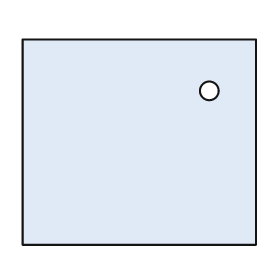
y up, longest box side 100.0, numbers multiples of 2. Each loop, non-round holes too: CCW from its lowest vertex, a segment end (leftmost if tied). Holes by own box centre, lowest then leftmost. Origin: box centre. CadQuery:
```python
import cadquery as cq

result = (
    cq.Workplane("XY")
    .moveTo(-50.0, -44.0)
    .lineTo(50.0, -44.0)
    .lineTo(50.0, 44.0)
    .lineTo(-50.0, 44.0)
    .close()
    .moveTo(30.0, 22.0)
    .circle(4.0)
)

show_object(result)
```